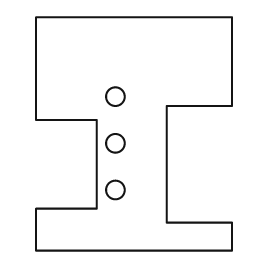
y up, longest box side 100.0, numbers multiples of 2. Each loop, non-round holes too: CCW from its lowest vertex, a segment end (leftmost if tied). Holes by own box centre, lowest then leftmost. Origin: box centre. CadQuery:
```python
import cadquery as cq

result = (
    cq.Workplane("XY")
    .moveTo(-42.0, -50.0)
    .lineTo(42.0, -50.0)
    .lineTo(42.0, -38.0)
    .lineTo(14.0, -38.0)
    .lineTo(14.0, 12.0)
    .lineTo(42.0, 12.0)
    .lineTo(42.0, 50.0)
    .lineTo(-42.0, 50.0)
    .lineTo(-42.0, 6.0)
    .lineTo(-16.0, 6.0)
    .lineTo(-16.0, -32.0)
    .lineTo(-42.0, -32.0)
    .close()
    .moveTo(-8.0, -24.0)
    .circle(4.0)
    .moveTo(-8.0, -4.0)
    .circle(4.0)
    .moveTo(-8.0, 16.0)
    .circle(4.0)
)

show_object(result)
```